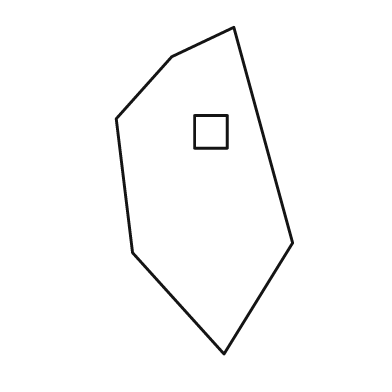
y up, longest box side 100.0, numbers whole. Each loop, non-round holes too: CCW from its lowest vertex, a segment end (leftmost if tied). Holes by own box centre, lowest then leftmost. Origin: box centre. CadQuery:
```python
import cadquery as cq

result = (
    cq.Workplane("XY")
    .moveTo(6.0, -50.0)
    .lineTo(27.0, -16.0)
    .lineTo(9.0, 50.0)
    .lineTo(-10.0, 41.0)
    .lineTo(-27.0, 22.0)
    .lineTo(-22.0, -19.0)
    .close()
    .moveTo(-3.0, 13.0)
    .lineTo(7.0, 13.0)
    .lineTo(7.0, 23.0)
    .lineTo(-3.0, 23.0)
    .close()
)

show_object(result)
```